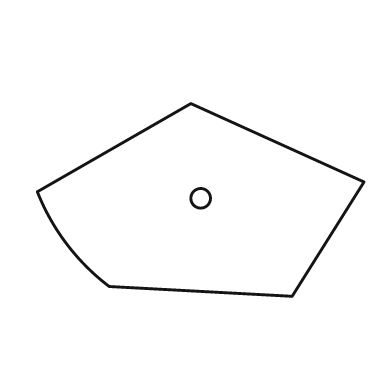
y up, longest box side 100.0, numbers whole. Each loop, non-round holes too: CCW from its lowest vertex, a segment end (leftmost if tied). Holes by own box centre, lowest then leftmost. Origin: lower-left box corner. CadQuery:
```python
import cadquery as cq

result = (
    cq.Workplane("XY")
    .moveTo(78.0, 0.0)
    .lineTo(100.0, 35.0)
    .lineTo(47.0, 59.0)
    .lineTo(0.0, 32.0)
    .threePointArc((9.0, 16.0), (22.0, 3.0))
    .close()
    .moveTo(50.0, 30.0)
    .circle(3.0)
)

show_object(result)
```